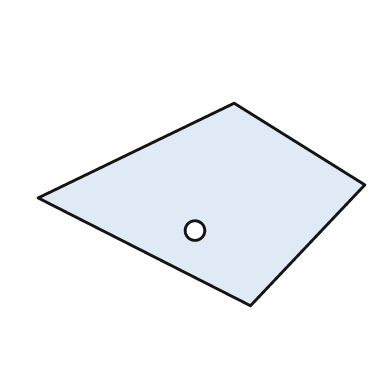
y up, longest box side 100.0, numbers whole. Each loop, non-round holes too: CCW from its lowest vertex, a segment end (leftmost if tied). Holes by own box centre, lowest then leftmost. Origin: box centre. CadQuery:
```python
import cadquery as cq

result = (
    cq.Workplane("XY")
    .moveTo(15.0, -31.0)
    .lineTo(50.0, 6.0)
    .lineTo(10.0, 31.0)
    .lineTo(-50.0, 2.0)
    .close()
    .moveTo(-2.0, -8.0)
    .circle(3.0)
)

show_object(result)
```